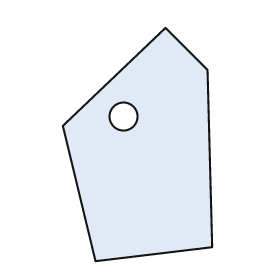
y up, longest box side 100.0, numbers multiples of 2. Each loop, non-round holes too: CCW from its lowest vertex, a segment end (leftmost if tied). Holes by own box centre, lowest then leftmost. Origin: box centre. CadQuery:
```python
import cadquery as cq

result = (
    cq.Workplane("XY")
    .moveTo(-18.0, -50.0)
    .lineTo(32.0, -44.0)
    .lineTo(30.0, 32.0)
    .lineTo(12.0, 50.0)
    .lineTo(-32.0, 8.0)
    .close()
    .moveTo(-6.0, 12.0)
    .circle(6.0)
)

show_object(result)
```